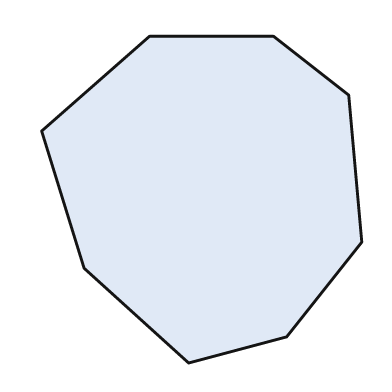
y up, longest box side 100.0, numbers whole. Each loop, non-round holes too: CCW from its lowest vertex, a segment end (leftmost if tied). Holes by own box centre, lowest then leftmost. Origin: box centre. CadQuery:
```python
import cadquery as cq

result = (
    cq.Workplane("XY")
    .moveTo(-4.0, -50.0)
    .lineTo(26.0, -42.0)
    .lineTo(49.0, -13.0)
    .lineTo(45.0, 32.0)
    .lineTo(22.0, 50.0)
    .lineTo(-16.0, 50.0)
    .lineTo(-49.0, 21.0)
    .lineTo(-36.0, -21.0)
    .close()
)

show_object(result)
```